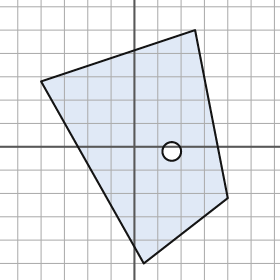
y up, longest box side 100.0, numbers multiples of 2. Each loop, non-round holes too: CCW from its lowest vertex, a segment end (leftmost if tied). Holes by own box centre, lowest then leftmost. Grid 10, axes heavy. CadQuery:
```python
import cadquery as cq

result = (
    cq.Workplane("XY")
    .moveTo(4.0, -50.0)
    .lineTo(40.0, -22.0)
    .lineTo(26.0, 50.0)
    .lineTo(-40.0, 28.0)
    .close()
    .moveTo(16.0, -2.0)
    .circle(4.0)
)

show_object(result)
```